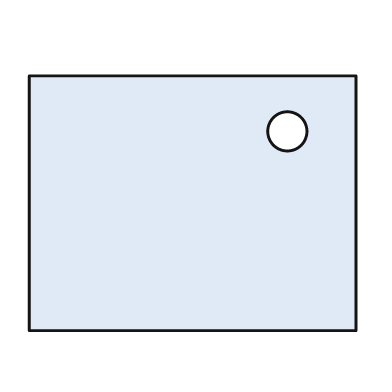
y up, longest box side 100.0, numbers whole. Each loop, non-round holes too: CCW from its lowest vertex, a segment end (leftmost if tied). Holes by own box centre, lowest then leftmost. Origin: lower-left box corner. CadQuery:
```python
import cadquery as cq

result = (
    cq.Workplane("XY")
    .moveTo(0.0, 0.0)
    .lineTo(100.0, 0.0)
    .lineTo(100.0, 78.0)
    .lineTo(0.0, 78.0)
    .close()
    .moveTo(79.0, 61.0)
    .circle(6.0)
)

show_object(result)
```